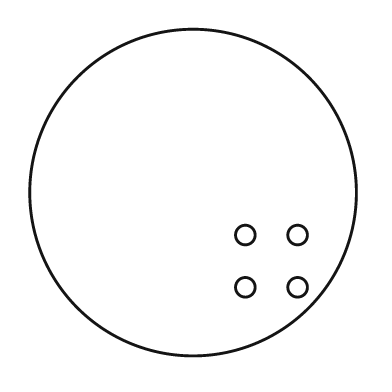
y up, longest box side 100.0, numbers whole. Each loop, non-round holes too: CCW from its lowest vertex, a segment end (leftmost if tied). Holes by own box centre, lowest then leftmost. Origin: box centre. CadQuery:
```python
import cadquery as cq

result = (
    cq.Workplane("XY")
    .moveTo(0.0, 0.0)
    .circle(50.0)
    .moveTo(16.0, -29.0)
    .circle(3.0)
    .moveTo(32.0, -29.0)
    .circle(3.0)
    .moveTo(16.0, -13.0)
    .circle(3.0)
    .moveTo(32.0, -13.0)
    .circle(3.0)
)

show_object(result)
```